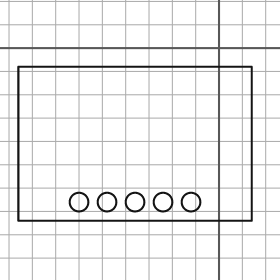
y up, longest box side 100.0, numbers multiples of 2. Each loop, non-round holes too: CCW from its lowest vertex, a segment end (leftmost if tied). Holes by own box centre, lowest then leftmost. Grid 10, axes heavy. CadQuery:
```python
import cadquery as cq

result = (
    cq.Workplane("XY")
    .moveTo(-86.0, -74.0)
    .lineTo(14.0, -74.0)
    .lineTo(14.0, -8.0)
    .lineTo(-86.0, -8.0)
    .close()
    .moveTo(-60.0, -66.0)
    .circle(4.0)
    .moveTo(-48.0, -66.0)
    .circle(4.0)
    .moveTo(-36.0, -66.0)
    .circle(4.0)
    .moveTo(-24.0, -66.0)
    .circle(4.0)
    .moveTo(-12.0, -66.0)
    .circle(4.0)
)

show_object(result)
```